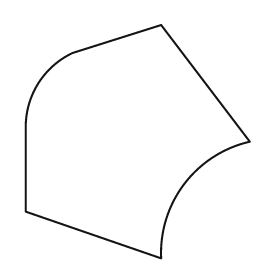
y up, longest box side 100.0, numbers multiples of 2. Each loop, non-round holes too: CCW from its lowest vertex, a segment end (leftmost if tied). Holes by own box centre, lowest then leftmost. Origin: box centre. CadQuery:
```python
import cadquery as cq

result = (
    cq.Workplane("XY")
    .moveTo(10.0, -50.0)
    .threePointArc((20.0, -18.0), (48.0, 0.0))
    .lineTo(10.0, 50.0)
    .lineTo(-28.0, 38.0)
    .threePointArc((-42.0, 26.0), (-48.0, 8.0))
    .lineTo(-48.0, -30.0)
    .close()
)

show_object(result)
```